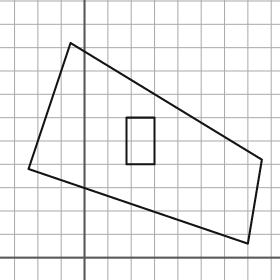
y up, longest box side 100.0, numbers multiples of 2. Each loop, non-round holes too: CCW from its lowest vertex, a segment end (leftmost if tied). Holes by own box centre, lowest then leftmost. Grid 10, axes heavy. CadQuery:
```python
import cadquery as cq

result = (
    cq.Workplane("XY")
    .moveTo(70.0, 6.0)
    .lineTo(76.0, 42.0)
    .lineTo(-6.0, 92.0)
    .lineTo(-24.0, 38.0)
    .close()
    .moveTo(18.0, 40.0)
    .lineTo(30.0, 40.0)
    .lineTo(30.0, 60.0)
    .lineTo(18.0, 60.0)
    .close()
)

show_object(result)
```